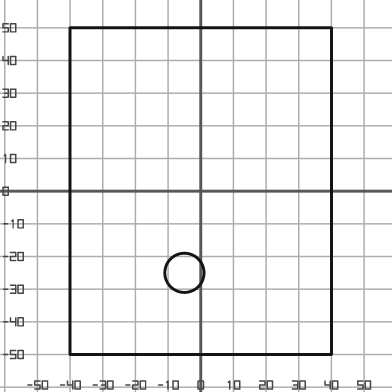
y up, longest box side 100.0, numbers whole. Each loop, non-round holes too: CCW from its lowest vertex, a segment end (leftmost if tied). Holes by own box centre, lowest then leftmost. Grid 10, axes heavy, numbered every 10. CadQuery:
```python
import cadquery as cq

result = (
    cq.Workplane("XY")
    .moveTo(-40.0, -50.0)
    .lineTo(40.0, -50.0)
    .lineTo(40.0, 50.0)
    .lineTo(-40.0, 50.0)
    .close()
    .moveTo(-5.0, -25.0)
    .circle(6.0)
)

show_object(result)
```